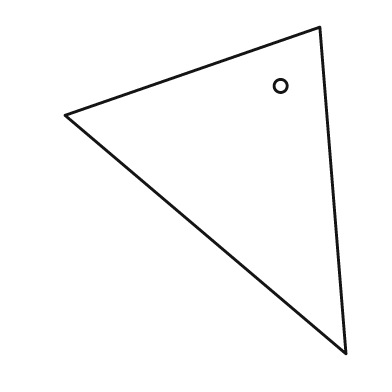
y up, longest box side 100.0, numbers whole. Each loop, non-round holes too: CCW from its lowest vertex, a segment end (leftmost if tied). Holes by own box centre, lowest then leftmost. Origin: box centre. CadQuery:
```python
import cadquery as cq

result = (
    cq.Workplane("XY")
    .moveTo(43.0, -50.0)
    .lineTo(35.0, 50.0)
    .lineTo(-43.0, 23.0)
    .close()
    .moveTo(23.0, 32.0)
    .circle(2.0)
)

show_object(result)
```